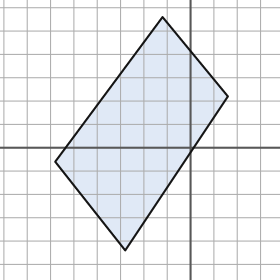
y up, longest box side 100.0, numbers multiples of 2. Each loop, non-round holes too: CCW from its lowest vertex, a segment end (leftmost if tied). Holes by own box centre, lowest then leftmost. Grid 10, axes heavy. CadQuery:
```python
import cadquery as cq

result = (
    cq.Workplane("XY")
    .moveTo(-28.0, -44.0)
    .lineTo(16.0, 22.0)
    .lineTo(-12.0, 56.0)
    .lineTo(-58.0, -6.0)
    .close()
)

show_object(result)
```